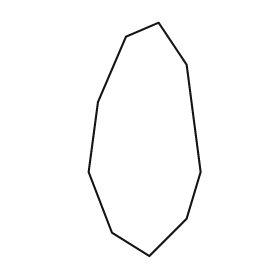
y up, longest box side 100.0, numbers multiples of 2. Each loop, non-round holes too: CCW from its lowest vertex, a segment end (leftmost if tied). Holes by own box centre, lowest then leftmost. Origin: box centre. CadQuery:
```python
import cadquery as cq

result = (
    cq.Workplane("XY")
    .moveTo(2.0, -50.0)
    .lineTo(18.0, -34.0)
    .lineTo(24.0, -14.0)
    .lineTo(18.0, 32.0)
    .lineTo(6.0, 50.0)
    .lineTo(-8.0, 44.0)
    .lineTo(-20.0, 16.0)
    .lineTo(-24.0, -14.0)
    .lineTo(-14.0, -40.0)
    .close()
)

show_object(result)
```